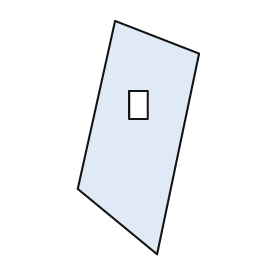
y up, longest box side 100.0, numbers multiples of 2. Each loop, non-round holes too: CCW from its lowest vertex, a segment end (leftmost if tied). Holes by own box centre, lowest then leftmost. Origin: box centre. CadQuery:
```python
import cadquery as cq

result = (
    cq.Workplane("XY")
    .moveTo(8.0, -50.0)
    .lineTo(26.0, 36.0)
    .lineTo(-10.0, 50.0)
    .lineTo(-26.0, -22.0)
    .close()
    .moveTo(-4.0, 8.0)
    .lineTo(4.0, 8.0)
    .lineTo(4.0, 20.0)
    .lineTo(-4.0, 20.0)
    .close()
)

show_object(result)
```